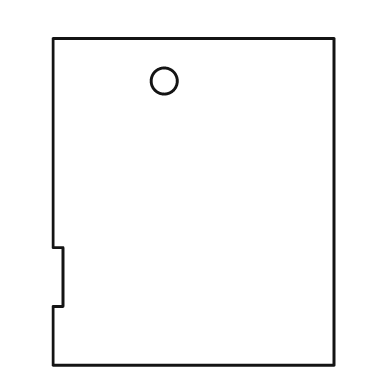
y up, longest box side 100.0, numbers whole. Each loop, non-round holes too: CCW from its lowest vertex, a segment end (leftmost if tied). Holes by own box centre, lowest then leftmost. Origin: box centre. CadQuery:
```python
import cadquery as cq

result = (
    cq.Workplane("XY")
    .moveTo(-43.0, -50.0)
    .lineTo(43.0, -50.0)
    .lineTo(43.0, 50.0)
    .lineTo(-43.0, 50.0)
    .lineTo(-43.0, -14.0)
    .lineTo(-40.0, -14.0)
    .lineTo(-40.0, -32.0)
    .lineTo(-43.0, -32.0)
    .close()
    .moveTo(-9.0, 37.0)
    .circle(4.0)
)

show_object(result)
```